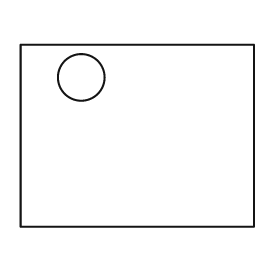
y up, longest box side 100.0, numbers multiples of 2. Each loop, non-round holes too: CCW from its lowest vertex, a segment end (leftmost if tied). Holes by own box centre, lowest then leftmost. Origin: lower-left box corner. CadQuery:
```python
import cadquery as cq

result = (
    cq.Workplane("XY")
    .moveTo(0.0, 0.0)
    .lineTo(100.0, 0.0)
    .lineTo(100.0, 78.0)
    .lineTo(0.0, 78.0)
    .close()
    .moveTo(26.0, 64.0)
    .circle(10.0)
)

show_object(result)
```